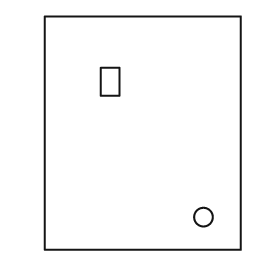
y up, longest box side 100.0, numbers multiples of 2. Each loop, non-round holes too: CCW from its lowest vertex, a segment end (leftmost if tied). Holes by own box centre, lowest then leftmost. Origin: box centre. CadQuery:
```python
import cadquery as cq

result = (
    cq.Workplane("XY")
    .moveTo(-42.0, -50.0)
    .lineTo(42.0, -50.0)
    .lineTo(42.0, 50.0)
    .lineTo(-42.0, 50.0)
    .close()
    .moveTo(26.0, -36.0)
    .circle(4.0)
    .moveTo(-18.0, 16.0)
    .lineTo(-10.0, 16.0)
    .lineTo(-10.0, 28.0)
    .lineTo(-18.0, 28.0)
    .close()
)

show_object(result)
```